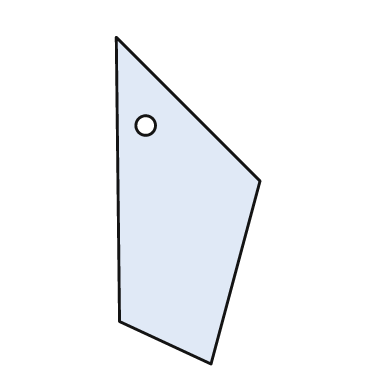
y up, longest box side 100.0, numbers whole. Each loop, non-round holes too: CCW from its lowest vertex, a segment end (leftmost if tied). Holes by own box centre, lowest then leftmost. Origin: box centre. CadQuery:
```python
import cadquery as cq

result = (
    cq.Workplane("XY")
    .moveTo(7.0, -50.0)
    .lineTo(22.0, 6.0)
    .lineTo(-22.0, 50.0)
    .lineTo(-21.0, -37.0)
    .close()
    .moveTo(-13.0, 23.0)
    .circle(3.0)
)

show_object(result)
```